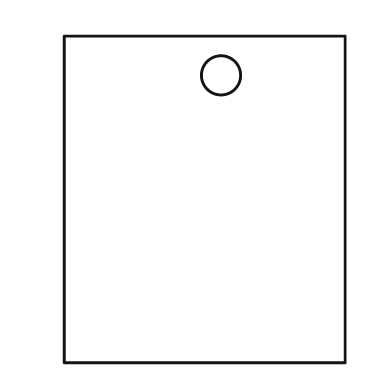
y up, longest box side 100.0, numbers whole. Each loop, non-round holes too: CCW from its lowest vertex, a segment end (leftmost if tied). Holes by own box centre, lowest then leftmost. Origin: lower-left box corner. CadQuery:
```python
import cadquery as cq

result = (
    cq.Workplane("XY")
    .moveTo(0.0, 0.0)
    .lineTo(86.0, 0.0)
    .lineTo(86.0, 100.0)
    .lineTo(0.0, 100.0)
    .close()
    .moveTo(48.0, 88.0)
    .circle(6.0)
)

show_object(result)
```